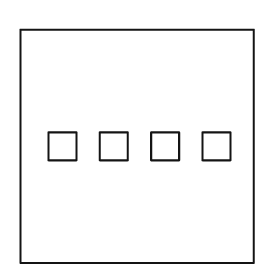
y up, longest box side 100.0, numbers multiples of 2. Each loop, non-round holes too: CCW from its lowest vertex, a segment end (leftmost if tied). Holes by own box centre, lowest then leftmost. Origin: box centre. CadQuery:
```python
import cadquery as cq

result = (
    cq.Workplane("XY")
    .moveTo(-50.0, -50.0)
    .lineTo(50.0, -50.0)
    .lineTo(50.0, 50.0)
    .lineTo(-50.0, 50.0)
    .close()
    .moveTo(-38.0, -6.0)
    .lineTo(-26.0, -6.0)
    .lineTo(-26.0, 6.0)
    .lineTo(-38.0, 6.0)
    .close()
    .moveTo(-16.0, -6.0)
    .lineTo(-4.0, -6.0)
    .lineTo(-4.0, 6.0)
    .lineTo(-16.0, 6.0)
    .close()
    .moveTo(6.0, -6.0)
    .lineTo(18.0, -6.0)
    .lineTo(18.0, 6.0)
    .lineTo(6.0, 6.0)
    .close()
    .moveTo(28.0, -6.0)
    .lineTo(40.0, -6.0)
    .lineTo(40.0, 6.0)
    .lineTo(28.0, 6.0)
    .close()
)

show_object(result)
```